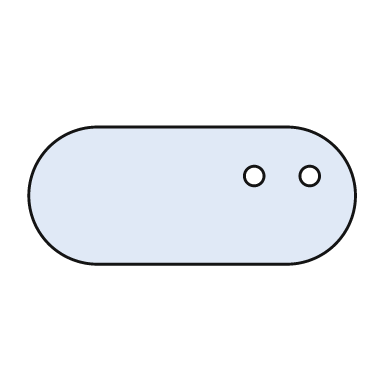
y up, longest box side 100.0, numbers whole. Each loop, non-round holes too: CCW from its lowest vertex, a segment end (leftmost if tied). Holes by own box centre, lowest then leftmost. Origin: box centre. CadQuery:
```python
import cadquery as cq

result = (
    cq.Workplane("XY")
    .moveTo(-29.0, -21.0)
    .lineTo(29.0, -21.0)
    .threePointArc((50.0, 0.0), (29.0, 21.0))
    .lineTo(-29.0, 21.0)
    .threePointArc((-50.0, 0.0), (-29.0, -21.0))
    .close()
    .moveTo(19.0, 6.0)
    .circle(3.0)
    .moveTo(36.0, 6.0)
    .circle(3.0)
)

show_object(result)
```